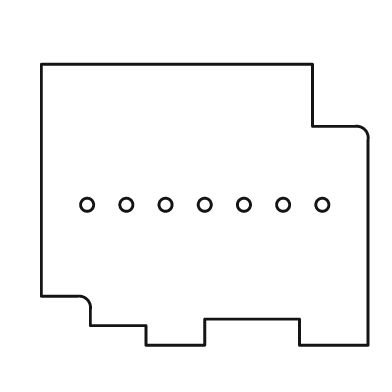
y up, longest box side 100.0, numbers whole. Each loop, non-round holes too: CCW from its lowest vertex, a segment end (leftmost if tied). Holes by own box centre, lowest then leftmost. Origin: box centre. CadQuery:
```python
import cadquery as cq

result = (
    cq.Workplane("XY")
    .moveTo(-18.0, -43.0)
    .lineTo(0.0, -43.0)
    .lineTo(0.0, -35.0)
    .lineTo(29.0, -35.0)
    .lineTo(29.0, -43.0)
    .lineTo(50.0, -43.0)
    .lineTo(50.0, 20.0)
    .threePointArc((49.0, 23.0), (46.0, 24.0))
    .lineTo(33.0, 24.0)
    .lineTo(33.0, 43.0)
    .lineTo(-50.0, 43.0)
    .lineTo(-50.0, -28.0)
    .lineTo(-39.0, -28.0)
    .threePointArc((-36.0, -29.0), (-35.0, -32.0))
    .lineTo(-35.0, -37.0)
    .lineTo(-18.0, -37.0)
    .close()
    .moveTo(-36.0, 0.0)
    .circle(2.0)
    .moveTo(-24.0, 0.0)
    .circle(2.0)
    .moveTo(-12.0, 0.0)
    .circle(2.0)
    .moveTo(0.0, 0.0)
    .circle(2.0)
    .moveTo(12.0, 0.0)
    .circle(2.0)
    .moveTo(24.0, 0.0)
    .circle(2.0)
    .moveTo(36.0, 0.0)
    .circle(2.0)
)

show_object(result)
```